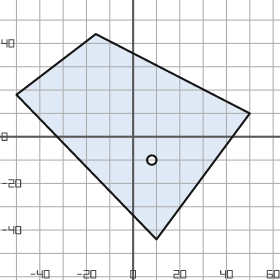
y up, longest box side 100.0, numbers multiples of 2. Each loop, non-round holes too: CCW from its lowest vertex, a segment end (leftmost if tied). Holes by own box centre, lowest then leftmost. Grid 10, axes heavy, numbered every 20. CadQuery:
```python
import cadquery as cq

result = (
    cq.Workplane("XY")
    .moveTo(10.0, -44.0)
    .lineTo(50.0, 10.0)
    .lineTo(-16.0, 44.0)
    .lineTo(-50.0, 18.0)
    .close()
    .moveTo(8.0, -10.0)
    .circle(2.0)
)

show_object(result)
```